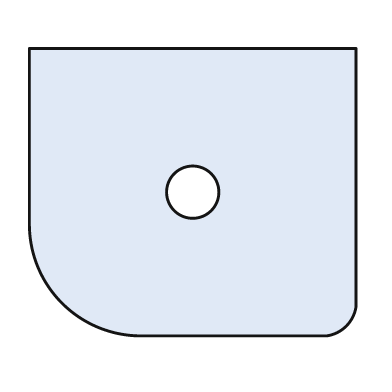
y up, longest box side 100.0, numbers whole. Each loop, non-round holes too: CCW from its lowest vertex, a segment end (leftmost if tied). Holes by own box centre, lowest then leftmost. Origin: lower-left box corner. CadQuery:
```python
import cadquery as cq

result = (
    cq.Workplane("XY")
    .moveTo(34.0, 0.0)
    .lineTo(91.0, 0.0)
    .threePointArc((97.0, 3.0), (100.0, 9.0))
    .lineTo(100.0, 88.0)
    .lineTo(0.0, 88.0)
    .lineTo(0.0, 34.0)
    .threePointArc((10.0, 10.0), (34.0, 0.0))
    .close()
    .moveTo(50.0, 44.0)
    .circle(8.0)
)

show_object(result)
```